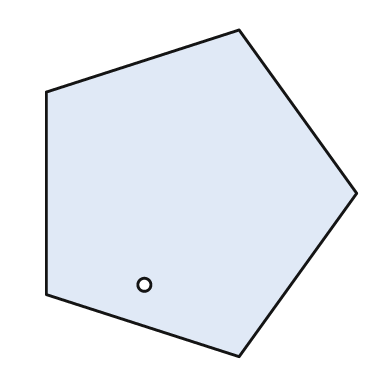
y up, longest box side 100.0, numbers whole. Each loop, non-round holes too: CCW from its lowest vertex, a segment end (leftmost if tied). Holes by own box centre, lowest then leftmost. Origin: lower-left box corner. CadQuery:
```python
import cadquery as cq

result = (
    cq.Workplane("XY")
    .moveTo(59.0, 0.0)
    .lineTo(95.0, 50.0)
    .lineTo(59.0, 100.0)
    .lineTo(0.0, 81.0)
    .lineTo(0.0, 19.0)
    .close()
    .moveTo(30.0, 22.0)
    .circle(2.0)
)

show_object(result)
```